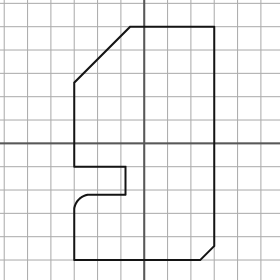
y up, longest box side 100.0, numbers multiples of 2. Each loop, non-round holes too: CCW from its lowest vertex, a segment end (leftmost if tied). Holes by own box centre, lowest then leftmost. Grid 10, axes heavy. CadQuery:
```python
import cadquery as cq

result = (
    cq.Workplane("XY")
    .moveTo(-30.0, -50.0)
    .lineTo(24.0, -50.0)
    .lineTo(30.0, -44.0)
    .lineTo(30.0, 50.0)
    .lineTo(-6.0, 50.0)
    .lineTo(-30.0, 26.0)
    .lineTo(-30.0, -10.0)
    .lineTo(-8.0, -10.0)
    .lineTo(-8.0, -22.0)
    .lineTo(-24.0, -22.0)
    .threePointArc((-28.0, -24.0), (-30.0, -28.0))
    .close()
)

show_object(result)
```